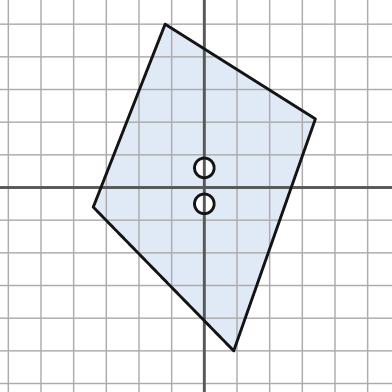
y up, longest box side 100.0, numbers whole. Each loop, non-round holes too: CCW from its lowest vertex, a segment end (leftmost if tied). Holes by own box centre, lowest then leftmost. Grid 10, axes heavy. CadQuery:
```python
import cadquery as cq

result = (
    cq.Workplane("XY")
    .moveTo(9.0, -50.0)
    .lineTo(34.0, 21.0)
    .lineTo(-12.0, 50.0)
    .lineTo(-34.0, -6.0)
    .close()
    .moveTo(0.0, -5.0)
    .circle(3.0)
    .moveTo(0.0, 6.0)
    .circle(3.0)
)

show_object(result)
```